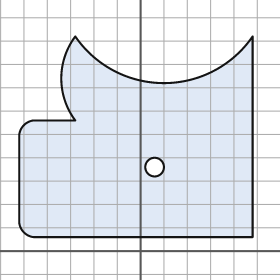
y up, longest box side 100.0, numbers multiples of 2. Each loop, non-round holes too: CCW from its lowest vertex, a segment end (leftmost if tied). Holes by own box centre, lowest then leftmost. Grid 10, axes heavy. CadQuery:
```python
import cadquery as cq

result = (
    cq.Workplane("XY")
    .moveTo(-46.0, 6.0)
    .lineTo(48.0, 6.0)
    .lineTo(48.0, 92.0)
    .threePointArc((10.0, 72.0), (-28.0, 92.0))
    .threePointArc((-34.0, 74.0), (-28.0, 56.0))
    .lineTo(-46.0, 56.0)
    .threePointArc((-50.0, 54.0), (-52.0, 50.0))
    .lineTo(-52.0, 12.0)
    .threePointArc((-50.0, 8.0), (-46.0, 6.0))
    .close()
    .moveTo(6.0, 36.0)
    .circle(4.0)
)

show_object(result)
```